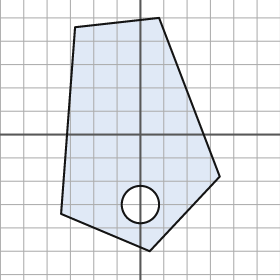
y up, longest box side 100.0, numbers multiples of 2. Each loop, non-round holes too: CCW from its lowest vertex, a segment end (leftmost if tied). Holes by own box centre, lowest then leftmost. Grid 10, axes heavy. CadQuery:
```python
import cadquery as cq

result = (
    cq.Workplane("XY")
    .moveTo(4.0, -50.0)
    .lineTo(34.0, -18.0)
    .lineTo(8.0, 50.0)
    .lineTo(-28.0, 46.0)
    .lineTo(-34.0, -34.0)
    .close()
    .moveTo(0.0, -30.0)
    .circle(8.0)
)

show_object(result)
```